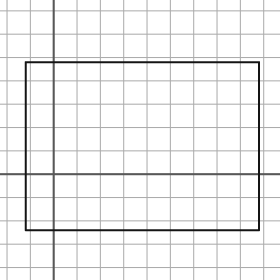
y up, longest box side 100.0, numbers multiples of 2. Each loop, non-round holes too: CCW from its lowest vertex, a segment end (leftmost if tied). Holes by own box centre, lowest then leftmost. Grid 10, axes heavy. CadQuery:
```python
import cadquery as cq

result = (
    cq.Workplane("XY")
    .moveTo(-12.0, -24.0)
    .lineTo(88.0, -24.0)
    .lineTo(88.0, 48.0)
    .lineTo(-12.0, 48.0)
    .close()
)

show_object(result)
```